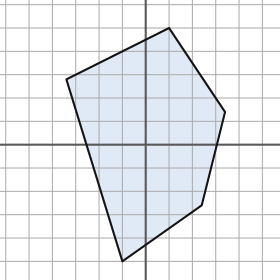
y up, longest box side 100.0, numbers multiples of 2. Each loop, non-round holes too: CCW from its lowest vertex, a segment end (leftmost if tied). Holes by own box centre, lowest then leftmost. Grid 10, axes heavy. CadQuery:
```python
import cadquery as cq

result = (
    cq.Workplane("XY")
    .moveTo(-10.0, -50.0)
    .lineTo(24.0, -26.0)
    .lineTo(34.0, 14.0)
    .lineTo(10.0, 50.0)
    .lineTo(-34.0, 28.0)
    .close()
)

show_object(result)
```